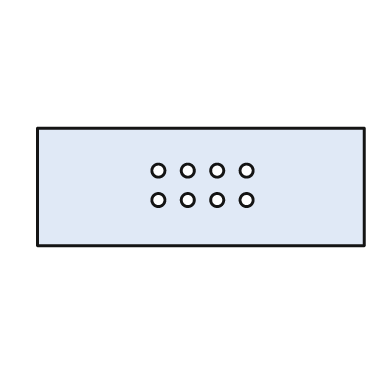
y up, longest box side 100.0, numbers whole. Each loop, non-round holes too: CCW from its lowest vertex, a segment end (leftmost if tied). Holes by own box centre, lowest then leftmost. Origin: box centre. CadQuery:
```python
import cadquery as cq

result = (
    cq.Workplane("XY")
    .moveTo(-50.0, -18.0)
    .lineTo(50.0, -18.0)
    .lineTo(50.0, 18.0)
    .lineTo(-50.0, 18.0)
    .close()
    .moveTo(-13.0, -4.0)
    .circle(2.0)
    .moveTo(-4.0, -4.0)
    .circle(2.0)
    .moveTo(5.0, -4.0)
    .circle(2.0)
    .moveTo(14.0, -4.0)
    .circle(2.0)
    .moveTo(-13.0, 5.0)
    .circle(2.0)
    .moveTo(-4.0, 5.0)
    .circle(2.0)
    .moveTo(5.0, 5.0)
    .circle(2.0)
    .moveTo(14.0, 5.0)
    .circle(2.0)
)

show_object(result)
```